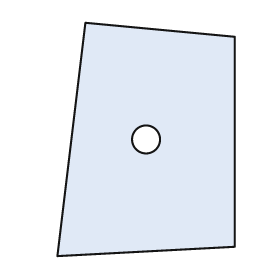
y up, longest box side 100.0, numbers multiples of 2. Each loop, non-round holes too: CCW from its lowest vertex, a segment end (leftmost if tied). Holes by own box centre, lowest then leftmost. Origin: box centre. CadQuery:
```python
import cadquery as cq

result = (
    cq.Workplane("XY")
    .moveTo(-38.0, -50.0)
    .lineTo(38.0, -46.0)
    .lineTo(38.0, 44.0)
    .lineTo(-26.0, 50.0)
    .close()
    .moveTo(0.0, 0.0)
    .circle(6.0)
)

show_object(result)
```